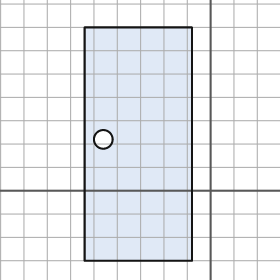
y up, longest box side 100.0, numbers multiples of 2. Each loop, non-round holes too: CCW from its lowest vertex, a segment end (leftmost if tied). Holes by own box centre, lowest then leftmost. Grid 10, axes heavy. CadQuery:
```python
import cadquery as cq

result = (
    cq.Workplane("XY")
    .moveTo(-54.0, -30.0)
    .lineTo(-8.0, -30.0)
    .lineTo(-8.0, 70.0)
    .lineTo(-54.0, 70.0)
    .close()
    .moveTo(-46.0, 22.0)
    .circle(4.0)
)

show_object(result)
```